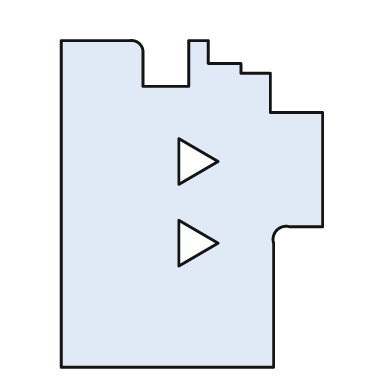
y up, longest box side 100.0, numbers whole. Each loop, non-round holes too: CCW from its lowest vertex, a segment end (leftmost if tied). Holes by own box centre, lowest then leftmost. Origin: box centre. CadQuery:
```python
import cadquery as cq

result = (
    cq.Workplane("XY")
    .moveTo(-40.0, -50.0)
    .lineTo(25.0, -50.0)
    .lineTo(25.0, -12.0)
    .threePointArc((26.0, -8.0), (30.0, -7.0))
    .lineTo(40.0, -7.0)
    .lineTo(40.0, 28.0)
    .lineTo(24.0, 28.0)
    .lineTo(24.0, 40.0)
    .lineTo(15.0, 40.0)
    .lineTo(15.0, 43.0)
    .lineTo(5.0, 43.0)
    .lineTo(5.0, 50.0)
    .lineTo(-1.0, 50.0)
    .lineTo(-1.0, 36.0)
    .lineTo(-15.0, 36.0)
    .lineTo(-15.0, 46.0)
    .threePointArc((-16.0, 49.0), (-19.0, 50.0))
    .lineTo(-40.0, 50.0)
    .close()
    .moveTo(-4.0, -19.0)
    .lineTo(8.0, -12.0)
    .lineTo(-4.0, -5.0)
    .close()
    .moveTo(-4.0, 6.0)
    .lineTo(8.0, 13.0)
    .lineTo(-4.0, 20.0)
    .close()
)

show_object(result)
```